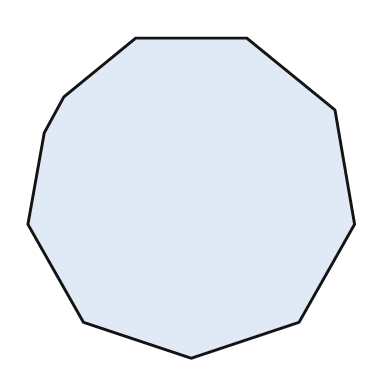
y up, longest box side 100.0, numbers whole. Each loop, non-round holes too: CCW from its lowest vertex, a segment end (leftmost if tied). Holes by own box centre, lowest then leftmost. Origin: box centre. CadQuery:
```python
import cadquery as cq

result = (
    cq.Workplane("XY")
    .moveTo(0.0, -49.0)
    .lineTo(33.0, -38.0)
    .lineTo(50.0, -8.0)
    .lineTo(44.0, 27.0)
    .lineTo(17.0, 49.0)
    .lineTo(-17.0, 49.0)
    .lineTo(-39.0, 31.0)
    .lineTo(-45.0, 20.0)
    .lineTo(-50.0, -8.0)
    .lineTo(-33.0, -38.0)
    .close()
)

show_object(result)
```